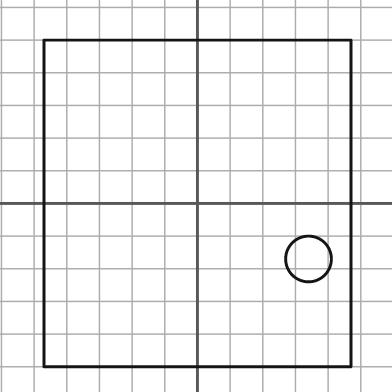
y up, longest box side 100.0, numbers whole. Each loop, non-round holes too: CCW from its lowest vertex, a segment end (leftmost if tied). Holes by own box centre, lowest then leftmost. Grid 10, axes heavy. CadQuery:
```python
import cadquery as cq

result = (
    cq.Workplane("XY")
    .moveTo(-47.0, -50.0)
    .lineTo(47.0, -50.0)
    .lineTo(47.0, 50.0)
    .lineTo(-47.0, 50.0)
    .close()
    .moveTo(34.0, -17.0)
    .circle(7.0)
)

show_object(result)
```